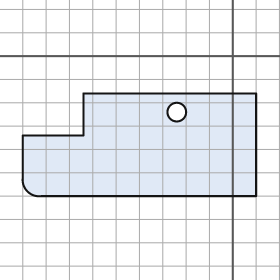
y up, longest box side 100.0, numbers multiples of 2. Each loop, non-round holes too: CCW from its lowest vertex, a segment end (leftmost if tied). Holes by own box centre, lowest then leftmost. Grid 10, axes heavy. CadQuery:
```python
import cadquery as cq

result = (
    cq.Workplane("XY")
    .moveTo(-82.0, -60.0)
    .lineTo(10.0, -60.0)
    .lineTo(10.0, -16.0)
    .lineTo(-64.0, -16.0)
    .lineTo(-64.0, -34.0)
    .lineTo(-90.0, -34.0)
    .lineTo(-90.0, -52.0)
    .threePointArc((-88.0, -58.0), (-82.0, -60.0))
    .close()
    .moveTo(-24.0, -24.0)
    .circle(4.0)
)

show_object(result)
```